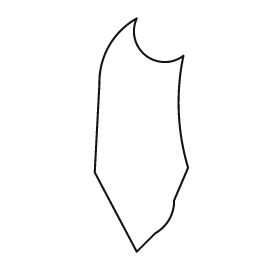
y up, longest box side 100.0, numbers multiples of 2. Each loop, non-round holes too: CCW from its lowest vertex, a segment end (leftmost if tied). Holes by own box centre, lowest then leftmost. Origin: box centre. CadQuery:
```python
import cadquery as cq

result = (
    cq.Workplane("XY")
    .moveTo(-2.0, -50.0)
    .lineTo(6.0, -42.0)
    .threePointArc((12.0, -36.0), (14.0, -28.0))
    .lineTo(20.0, -14.0)
    .threePointArc((16.0, 10.0), (18.0, 34.0))
    .threePointArc((2.0, 34.0), (-2.0, 50.0))
    .threePointArc((-14.0, 38.0), (-18.0, 22.0))
    .lineTo(-20.0, -16.0)
    .close()
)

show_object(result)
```